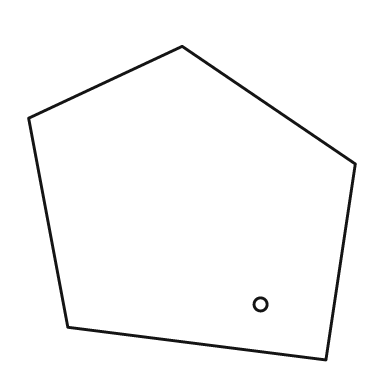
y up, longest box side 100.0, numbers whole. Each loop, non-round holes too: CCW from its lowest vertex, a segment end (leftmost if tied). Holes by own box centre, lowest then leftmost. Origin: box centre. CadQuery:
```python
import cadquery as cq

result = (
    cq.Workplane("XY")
    .moveTo(41.0, -48.0)
    .lineTo(50.0, 12.0)
    .lineTo(-3.0, 48.0)
    .lineTo(-50.0, 26.0)
    .lineTo(-38.0, -38.0)
    .close()
    .moveTo(21.0, -31.0)
    .circle(2.0)
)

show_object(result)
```